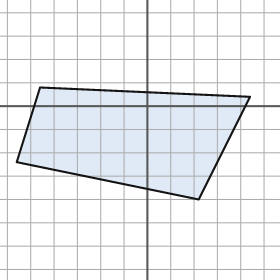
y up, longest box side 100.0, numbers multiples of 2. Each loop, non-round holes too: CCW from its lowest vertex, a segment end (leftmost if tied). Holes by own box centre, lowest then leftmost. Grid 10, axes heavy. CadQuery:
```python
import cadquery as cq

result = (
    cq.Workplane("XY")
    .moveTo(22.0, -40.0)
    .lineTo(44.0, 4.0)
    .lineTo(-46.0, 8.0)
    .lineTo(-56.0, -24.0)
    .close()
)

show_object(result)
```